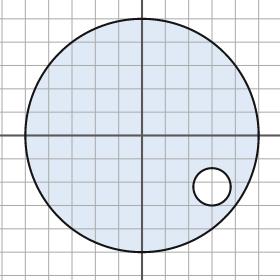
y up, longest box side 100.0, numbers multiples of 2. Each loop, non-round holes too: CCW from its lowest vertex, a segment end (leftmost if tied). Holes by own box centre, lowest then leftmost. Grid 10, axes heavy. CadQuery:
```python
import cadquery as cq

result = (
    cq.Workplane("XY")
    .moveTo(0.0, 0.0)
    .circle(50.0)
    .moveTo(30.0, -22.0)
    .circle(8.0)
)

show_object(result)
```